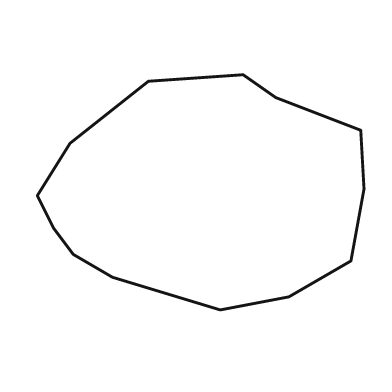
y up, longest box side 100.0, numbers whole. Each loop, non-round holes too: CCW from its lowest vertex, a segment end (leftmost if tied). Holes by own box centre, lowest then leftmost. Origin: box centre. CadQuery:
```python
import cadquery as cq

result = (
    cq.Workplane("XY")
    .moveTo(6.0, -36.0)
    .lineTo(27.0, -32.0)
    .lineTo(46.0, -21.0)
    .lineTo(50.0, 1.0)
    .lineTo(49.0, 19.0)
    .lineTo(23.0, 29.0)
    .lineTo(13.0, 36.0)
    .lineTo(-16.0, 34.0)
    .lineTo(-40.0, 15.0)
    .lineTo(-50.0, -1.0)
    .lineTo(-45.0, -11.0)
    .lineTo(-39.0, -19.0)
    .lineTo(-27.0, -26.0)
    .close()
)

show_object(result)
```